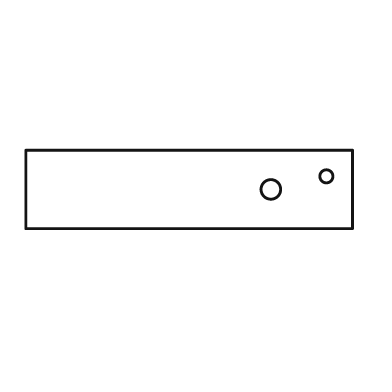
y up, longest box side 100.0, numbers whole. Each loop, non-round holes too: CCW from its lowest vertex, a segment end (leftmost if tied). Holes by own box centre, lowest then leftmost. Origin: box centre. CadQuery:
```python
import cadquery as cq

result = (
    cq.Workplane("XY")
    .moveTo(-50.0, -12.0)
    .lineTo(50.0, -12.0)
    .lineTo(50.0, 12.0)
    .lineTo(-50.0, 12.0)
    .close()
    .moveTo(25.0, 0.0)
    .circle(3.0)
    .moveTo(42.0, 4.0)
    .circle(2.0)
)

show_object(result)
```